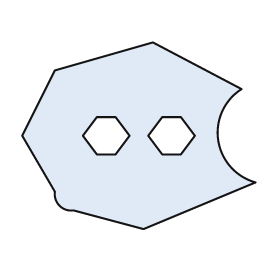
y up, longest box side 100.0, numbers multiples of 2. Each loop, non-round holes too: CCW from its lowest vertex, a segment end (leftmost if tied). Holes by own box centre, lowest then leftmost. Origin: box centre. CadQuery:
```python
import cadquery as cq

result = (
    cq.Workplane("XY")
    .moveTo(2.0, -40.0)
    .lineTo(50.0, -20.0)
    .threePointArc((34.0, -2.0), (44.0, 20.0))
    .lineTo(6.0, 40.0)
    .lineTo(-36.0, 28.0)
    .lineTo(-50.0, 0.0)
    .lineTo(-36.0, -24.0)
    .threePointArc((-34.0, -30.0), (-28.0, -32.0))
    .close()
    .moveTo(-18.0, -8.0)
    .lineTo(-10.0, -8.0)
    .lineTo(-4.0, 0.0)
    .lineTo(-10.0, 8.0)
    .lineTo(-18.0, 8.0)
    .lineTo(-24.0, 0.0)
    .close()
    .moveTo(10.0, -8.0)
    .lineTo(18.0, -8.0)
    .lineTo(24.0, 0.0)
    .lineTo(18.0, 8.0)
    .lineTo(10.0, 8.0)
    .lineTo(4.0, 0.0)
    .close()
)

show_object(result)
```